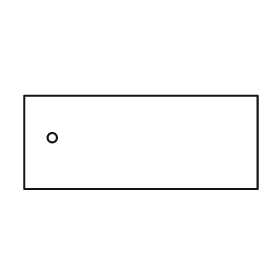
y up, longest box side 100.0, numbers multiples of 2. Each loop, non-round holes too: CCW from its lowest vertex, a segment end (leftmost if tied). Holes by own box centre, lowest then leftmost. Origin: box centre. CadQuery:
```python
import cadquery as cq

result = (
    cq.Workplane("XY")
    .moveTo(-50.0, -20.0)
    .lineTo(50.0, -20.0)
    .lineTo(50.0, 20.0)
    .lineTo(-50.0, 20.0)
    .close()
    .moveTo(-38.0, 2.0)
    .circle(2.0)
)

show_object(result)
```